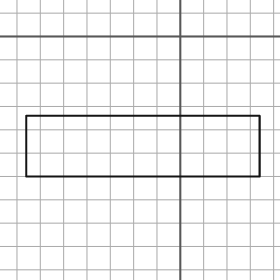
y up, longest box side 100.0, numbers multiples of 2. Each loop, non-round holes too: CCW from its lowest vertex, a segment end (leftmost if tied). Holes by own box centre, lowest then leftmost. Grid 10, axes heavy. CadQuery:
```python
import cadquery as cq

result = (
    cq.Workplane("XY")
    .moveTo(-66.0, -60.0)
    .lineTo(34.0, -60.0)
    .lineTo(34.0, -34.0)
    .lineTo(-66.0, -34.0)
    .close()
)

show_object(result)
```